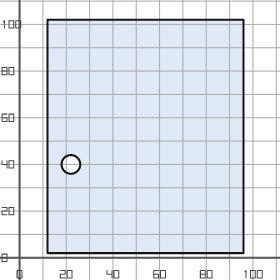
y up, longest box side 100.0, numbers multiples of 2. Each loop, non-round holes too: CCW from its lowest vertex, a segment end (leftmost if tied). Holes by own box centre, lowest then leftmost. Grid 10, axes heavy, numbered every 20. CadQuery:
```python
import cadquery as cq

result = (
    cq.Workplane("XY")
    .moveTo(12.0, 2.0)
    .lineTo(96.0, 2.0)
    .lineTo(96.0, 102.0)
    .lineTo(12.0, 102.0)
    .close()
    .moveTo(22.0, 40.0)
    .circle(4.0)
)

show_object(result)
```